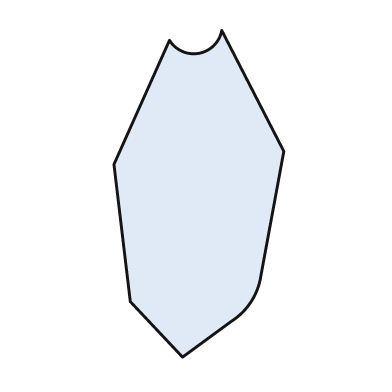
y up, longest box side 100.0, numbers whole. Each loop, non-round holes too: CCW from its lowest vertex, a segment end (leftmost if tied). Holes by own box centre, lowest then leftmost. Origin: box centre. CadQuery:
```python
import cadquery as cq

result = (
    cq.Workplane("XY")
    .moveTo(-5.0, -50.0)
    .lineTo(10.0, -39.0)
    .threePointArc((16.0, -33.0), (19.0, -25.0))
    .lineTo(26.0, 13.0)
    .lineTo(7.0, 50.0)
    .threePointArc((0.0, 43.0), (-9.0, 47.0))
    .lineTo(-26.0, 9.0)
    .lineTo(-21.0, -33.0)
    .close()
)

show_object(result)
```